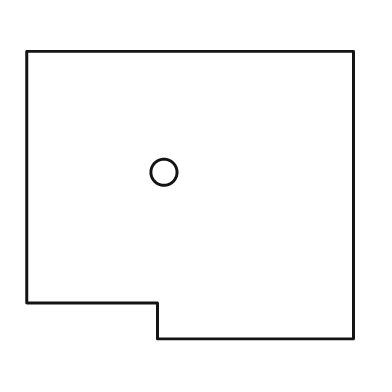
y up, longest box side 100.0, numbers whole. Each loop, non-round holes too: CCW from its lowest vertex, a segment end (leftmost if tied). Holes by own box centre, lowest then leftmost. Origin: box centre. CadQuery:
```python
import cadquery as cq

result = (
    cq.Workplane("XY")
    .moveTo(-10.0, -44.0)
    .lineTo(50.0, -44.0)
    .lineTo(50.0, 44.0)
    .lineTo(-50.0, 44.0)
    .lineTo(-50.0, -33.0)
    .lineTo(-10.0, -33.0)
    .close()
    .moveTo(-8.0, 7.0)
    .circle(4.0)
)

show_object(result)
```